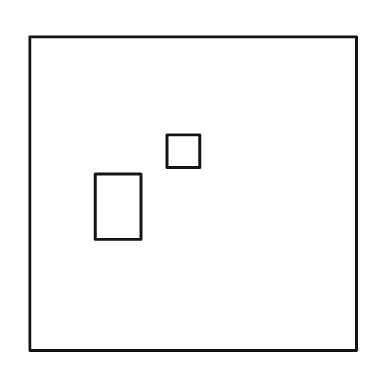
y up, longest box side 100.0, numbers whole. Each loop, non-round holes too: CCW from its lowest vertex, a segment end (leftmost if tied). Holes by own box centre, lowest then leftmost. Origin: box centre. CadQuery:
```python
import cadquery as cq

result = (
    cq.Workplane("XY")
    .moveTo(-50.0, -48.0)
    .lineTo(50.0, -48.0)
    .lineTo(50.0, 48.0)
    .lineTo(-50.0, 48.0)
    .close()
    .moveTo(-30.0, -14.0)
    .lineTo(-16.0, -14.0)
    .lineTo(-16.0, 6.0)
    .lineTo(-30.0, 6.0)
    .close()
    .moveTo(-8.0, 8.0)
    .lineTo(2.0, 8.0)
    .lineTo(2.0, 18.0)
    .lineTo(-8.0, 18.0)
    .close()
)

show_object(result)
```